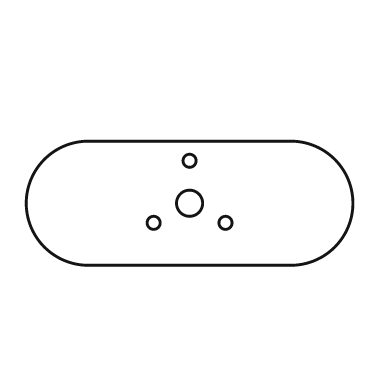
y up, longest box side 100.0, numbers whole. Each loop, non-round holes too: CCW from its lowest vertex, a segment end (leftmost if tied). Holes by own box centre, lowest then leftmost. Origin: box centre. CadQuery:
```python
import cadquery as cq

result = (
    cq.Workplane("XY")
    .moveTo(-31.0, -19.0)
    .lineTo(31.0, -19.0)
    .threePointArc((50.0, 0.0), (31.0, 19.0))
    .lineTo(-31.0, 19.0)
    .threePointArc((-50.0, 0.0), (-31.0, -19.0))
    .close()
    .moveTo(-11.0, -6.0)
    .circle(2.0)
    .moveTo(11.0, -6.0)
    .circle(2.0)
    .moveTo(0.0, 0.0)
    .circle(4.0)
    .moveTo(0.0, 13.0)
    .circle(2.0)
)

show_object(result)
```